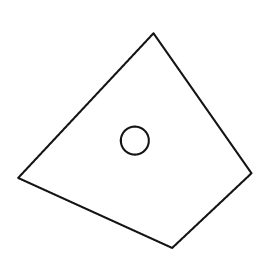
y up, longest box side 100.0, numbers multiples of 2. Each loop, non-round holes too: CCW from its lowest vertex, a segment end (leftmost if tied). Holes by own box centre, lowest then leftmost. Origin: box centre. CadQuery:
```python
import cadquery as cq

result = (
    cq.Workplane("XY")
    .moveTo(16.0, -46.0)
    .lineTo(50.0, -14.0)
    .lineTo(8.0, 46.0)
    .lineTo(-50.0, -16.0)
    .close()
    .moveTo(0.0, 0.0)
    .circle(6.0)
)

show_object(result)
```